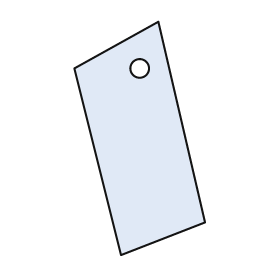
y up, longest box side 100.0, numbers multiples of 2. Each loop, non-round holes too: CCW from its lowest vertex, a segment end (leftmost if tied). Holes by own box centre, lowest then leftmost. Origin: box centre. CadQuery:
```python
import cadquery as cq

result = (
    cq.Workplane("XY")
    .moveTo(-8.0, -50.0)
    .lineTo(28.0, -36.0)
    .lineTo(8.0, 50.0)
    .lineTo(-28.0, 30.0)
    .close()
    .moveTo(0.0, 30.0)
    .circle(4.0)
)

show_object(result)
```